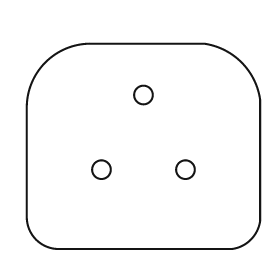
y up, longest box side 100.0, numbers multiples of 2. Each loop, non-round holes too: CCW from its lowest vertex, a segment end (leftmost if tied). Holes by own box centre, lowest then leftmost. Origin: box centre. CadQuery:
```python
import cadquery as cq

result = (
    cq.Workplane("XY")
    .moveTo(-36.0, -44.0)
    .lineTo(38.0, -44.0)
    .threePointArc((46.0, -40.0), (50.0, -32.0))
    .lineTo(50.0, 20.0)
    .threePointArc((42.0, 36.0), (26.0, 44.0))
    .lineTo(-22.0, 44.0)
    .threePointArc((-42.0, 36.0), (-50.0, 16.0))
    .lineTo(-50.0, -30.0)
    .threePointArc((-46.0, -40.0), (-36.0, -44.0))
    .close()
    .moveTo(-18.0, -10.0)
    .circle(4.0)
    .moveTo(18.0, -10.0)
    .circle(4.0)
    .moveTo(0.0, 22.0)
    .circle(4.0)
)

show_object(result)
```